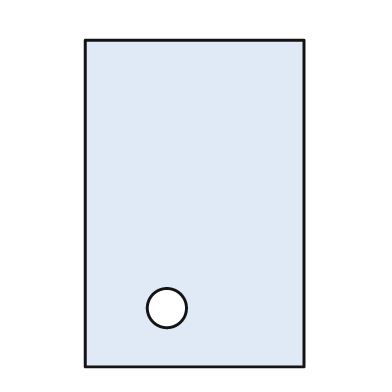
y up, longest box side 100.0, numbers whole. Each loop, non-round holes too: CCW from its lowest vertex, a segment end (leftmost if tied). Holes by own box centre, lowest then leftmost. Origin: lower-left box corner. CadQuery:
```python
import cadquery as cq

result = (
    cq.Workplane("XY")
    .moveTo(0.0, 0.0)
    .lineTo(67.0, 0.0)
    .lineTo(67.0, 100.0)
    .lineTo(0.0, 100.0)
    .close()
    .moveTo(25.0, 18.0)
    .circle(6.0)
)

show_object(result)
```